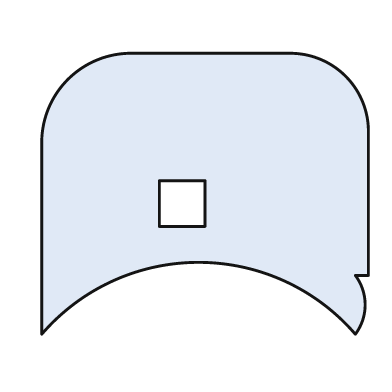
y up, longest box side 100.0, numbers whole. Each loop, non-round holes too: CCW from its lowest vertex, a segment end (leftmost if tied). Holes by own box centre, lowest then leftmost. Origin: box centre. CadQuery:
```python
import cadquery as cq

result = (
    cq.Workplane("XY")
    .moveTo(-50.0, -43.0)
    .threePointArc((-2.0, -21.0), (46.0, -43.0))
    .threePointArc((49.0, -34.0), (46.0, -25.0))
    .lineTo(50.0, -25.0)
    .lineTo(50.0, 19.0)
    .threePointArc((43.0, 36.0), (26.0, 43.0))
    .lineTo(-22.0, 43.0)
    .threePointArc((-42.0, 35.0), (-50.0, 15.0))
    .close()
    .moveTo(-14.0, -10.0)
    .lineTo(0.0, -10.0)
    .lineTo(0.0, 4.0)
    .lineTo(-14.0, 4.0)
    .close()
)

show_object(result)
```